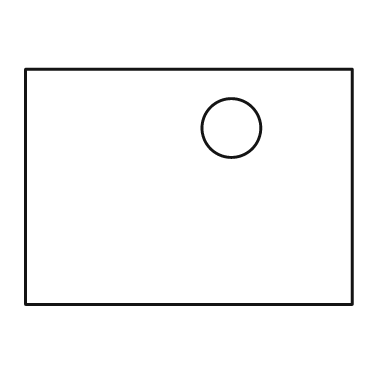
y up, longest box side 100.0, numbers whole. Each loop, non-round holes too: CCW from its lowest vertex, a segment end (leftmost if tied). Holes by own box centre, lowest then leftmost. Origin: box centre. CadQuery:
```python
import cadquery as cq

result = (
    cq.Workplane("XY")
    .moveTo(-50.0, -36.0)
    .lineTo(50.0, -36.0)
    .lineTo(50.0, 36.0)
    .lineTo(-50.0, 36.0)
    .close()
    .moveTo(13.0, 18.0)
    .circle(9.0)
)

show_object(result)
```